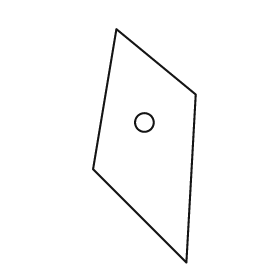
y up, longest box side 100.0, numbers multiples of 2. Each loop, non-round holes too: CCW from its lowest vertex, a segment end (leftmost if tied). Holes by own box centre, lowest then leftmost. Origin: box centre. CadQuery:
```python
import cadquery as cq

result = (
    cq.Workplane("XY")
    .moveTo(18.0, -50.0)
    .lineTo(22.0, 22.0)
    .lineTo(-12.0, 50.0)
    .lineTo(-22.0, -10.0)
    .close()
    .moveTo(0.0, 10.0)
    .circle(4.0)
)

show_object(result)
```